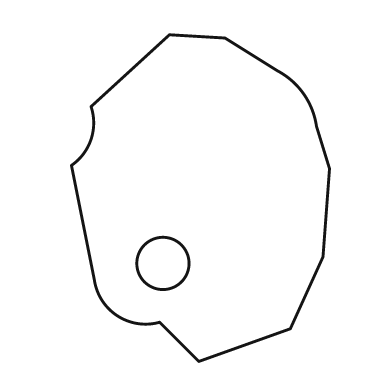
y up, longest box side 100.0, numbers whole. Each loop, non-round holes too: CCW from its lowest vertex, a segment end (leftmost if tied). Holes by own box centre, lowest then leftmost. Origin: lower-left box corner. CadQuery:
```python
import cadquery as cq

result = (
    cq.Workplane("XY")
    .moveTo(39.0, 0.0)
    .lineTo(67.0, 10.0)
    .lineTo(77.0, 32.0)
    .lineTo(79.0, 59.0)
    .lineTo(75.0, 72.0)
    .threePointArc((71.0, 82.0), (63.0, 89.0))
    .lineTo(47.0, 99.0)
    .lineTo(30.0, 100.0)
    .lineTo(6.0, 78.0)
    .threePointArc((6.0, 68.0), (0.0, 60.0))
    .lineTo(7.0, 25.0)
    .threePointArc((14.0, 14.0), (27.0, 12.0))
    .close()
    .moveTo(28.0, 30.0)
    .circle(8.0)
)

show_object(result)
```